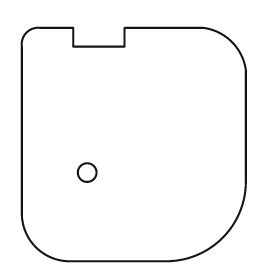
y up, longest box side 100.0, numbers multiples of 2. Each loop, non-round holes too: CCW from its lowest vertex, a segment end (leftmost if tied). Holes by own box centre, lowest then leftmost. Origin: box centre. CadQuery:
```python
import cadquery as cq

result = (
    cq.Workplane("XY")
    .moveTo(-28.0, -50.0)
    .lineTo(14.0, -50.0)
    .threePointArc((38.0, -40.0), (48.0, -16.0))
    .lineTo(48.0, 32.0)
    .threePointArc((42.0, 44.0), (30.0, 50.0))
    .lineTo(-4.0, 50.0)
    .lineTo(-4.0, 42.0)
    .lineTo(-26.0, 42.0)
    .lineTo(-26.0, 50.0)
    .lineTo(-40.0, 50.0)
    .threePointArc((-46.0, 48.0), (-48.0, 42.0))
    .lineTo(-48.0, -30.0)
    .threePointArc((-42.0, -44.0), (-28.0, -50.0))
    .close()
    .moveTo(-20.0, -12.0)
    .circle(4.0)
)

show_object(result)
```